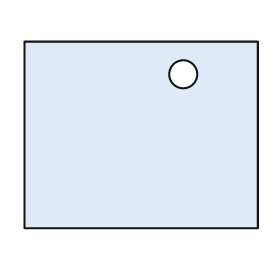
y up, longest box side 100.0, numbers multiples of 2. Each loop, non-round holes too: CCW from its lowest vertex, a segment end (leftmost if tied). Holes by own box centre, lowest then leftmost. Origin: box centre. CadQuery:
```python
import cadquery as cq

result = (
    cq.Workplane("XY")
    .moveTo(-50.0, -40.0)
    .lineTo(50.0, -40.0)
    .lineTo(50.0, 40.0)
    .lineTo(-50.0, 40.0)
    .close()
    .moveTo(18.0, 26.0)
    .circle(6.0)
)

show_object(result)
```